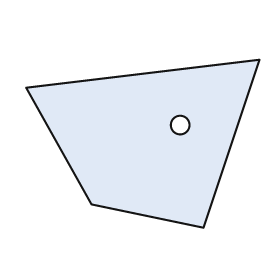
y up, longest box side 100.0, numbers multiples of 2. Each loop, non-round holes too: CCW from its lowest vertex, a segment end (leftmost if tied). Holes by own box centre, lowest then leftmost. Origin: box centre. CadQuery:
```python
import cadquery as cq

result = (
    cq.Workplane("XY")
    .moveTo(26.0, -36.0)
    .lineTo(50.0, 36.0)
    .lineTo(-50.0, 24.0)
    .lineTo(-22.0, -26.0)
    .close()
    .moveTo(16.0, 8.0)
    .circle(4.0)
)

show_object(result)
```